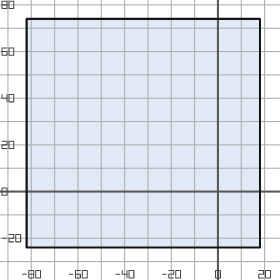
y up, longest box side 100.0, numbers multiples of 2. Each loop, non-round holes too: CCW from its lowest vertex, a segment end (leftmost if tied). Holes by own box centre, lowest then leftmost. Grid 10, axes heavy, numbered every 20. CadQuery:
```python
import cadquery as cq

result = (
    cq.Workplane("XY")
    .moveTo(-82.0, -24.0)
    .lineTo(18.0, -24.0)
    .lineTo(18.0, 74.0)
    .lineTo(-82.0, 74.0)
    .close()
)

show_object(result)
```